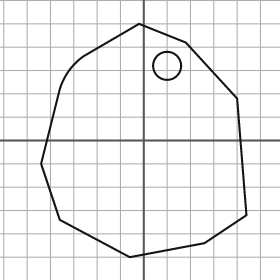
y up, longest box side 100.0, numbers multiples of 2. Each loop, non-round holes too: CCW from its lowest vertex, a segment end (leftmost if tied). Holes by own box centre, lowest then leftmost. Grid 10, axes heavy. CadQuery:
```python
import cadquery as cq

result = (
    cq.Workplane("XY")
    .moveTo(-6.0, -50.0)
    .lineTo(26.0, -44.0)
    .lineTo(44.0, -32.0)
    .lineTo(40.0, 18.0)
    .lineTo(18.0, 42.0)
    .lineTo(-2.0, 50.0)
    .lineTo(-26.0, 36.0)
    .threePointArc((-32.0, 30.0), (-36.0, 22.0))
    .lineTo(-44.0, -10.0)
    .lineTo(-36.0, -34.0)
    .close()
    .moveTo(10.0, 32.0)
    .circle(6.0)
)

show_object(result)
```